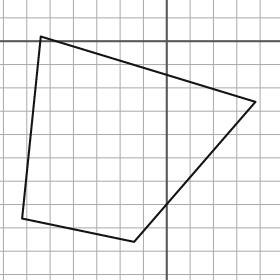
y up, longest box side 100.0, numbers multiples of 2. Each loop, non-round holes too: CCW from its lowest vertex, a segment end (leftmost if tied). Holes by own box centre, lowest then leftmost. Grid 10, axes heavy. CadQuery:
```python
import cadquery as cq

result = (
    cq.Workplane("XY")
    .moveTo(-14.0, -86.0)
    .lineTo(38.0, -26.0)
    .lineTo(-54.0, 2.0)
    .lineTo(-62.0, -76.0)
    .close()
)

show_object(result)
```